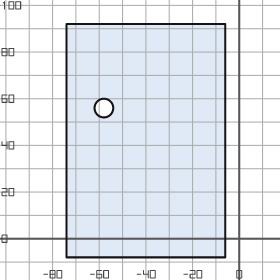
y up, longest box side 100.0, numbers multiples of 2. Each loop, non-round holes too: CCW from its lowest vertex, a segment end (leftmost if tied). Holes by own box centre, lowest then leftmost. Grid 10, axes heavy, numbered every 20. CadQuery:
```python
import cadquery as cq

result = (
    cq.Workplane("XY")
    .moveTo(-74.0, -8.0)
    .lineTo(-6.0, -8.0)
    .lineTo(-6.0, 92.0)
    .lineTo(-74.0, 92.0)
    .close()
    .moveTo(-58.0, 56.0)
    .circle(4.0)
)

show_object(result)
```